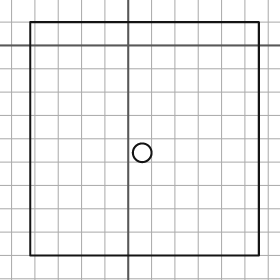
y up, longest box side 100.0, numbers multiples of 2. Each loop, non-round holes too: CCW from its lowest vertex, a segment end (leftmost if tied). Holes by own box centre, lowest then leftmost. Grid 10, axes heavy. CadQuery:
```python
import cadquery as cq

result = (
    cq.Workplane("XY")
    .moveTo(-42.0, -90.0)
    .lineTo(56.0, -90.0)
    .lineTo(56.0, 10.0)
    .lineTo(-42.0, 10.0)
    .close()
    .moveTo(6.0, -46.0)
    .circle(4.0)
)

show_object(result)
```